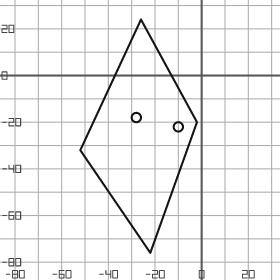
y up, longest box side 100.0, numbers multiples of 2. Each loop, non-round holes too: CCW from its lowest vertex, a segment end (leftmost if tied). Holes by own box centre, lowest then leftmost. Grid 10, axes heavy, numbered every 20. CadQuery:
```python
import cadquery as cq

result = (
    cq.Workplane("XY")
    .moveTo(-22.0, -76.0)
    .lineTo(-2.0, -20.0)
    .lineTo(-26.0, 24.0)
    .lineTo(-52.0, -32.0)
    .close()
    .moveTo(-10.0, -22.0)
    .circle(2.0)
    .moveTo(-28.0, -18.0)
    .circle(2.0)
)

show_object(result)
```